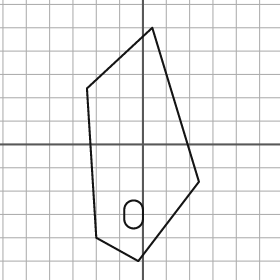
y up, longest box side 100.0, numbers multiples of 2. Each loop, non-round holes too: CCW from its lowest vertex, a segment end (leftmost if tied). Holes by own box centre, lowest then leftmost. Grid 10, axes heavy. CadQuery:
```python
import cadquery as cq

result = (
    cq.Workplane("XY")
    .moveTo(-2.0, -50.0)
    .lineTo(24.0, -16.0)
    .lineTo(4.0, 50.0)
    .lineTo(-24.0, 24.0)
    .lineTo(-20.0, -40.0)
    .close()
    .moveTo(-8.0, -32.0)
    .threePointArc((-4.0, -36.0), (0.0, -32.0))
    .lineTo(0.0, -28.0)
    .threePointArc((-4.0, -24.0), (-8.0, -28.0))
    .close()
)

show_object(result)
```